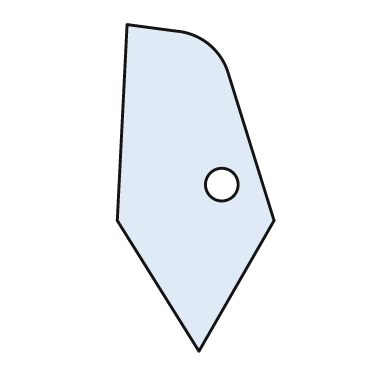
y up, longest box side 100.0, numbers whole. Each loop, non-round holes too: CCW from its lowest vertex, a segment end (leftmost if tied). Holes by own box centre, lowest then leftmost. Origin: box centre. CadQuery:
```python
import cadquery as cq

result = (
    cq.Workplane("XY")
    .moveTo(1.0, -50.0)
    .lineTo(24.0, -10.0)
    .lineTo(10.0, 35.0)
    .threePointArc((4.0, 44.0), (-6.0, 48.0))
    .lineTo(-21.0, 50.0)
    .lineTo(-24.0, -10.0)
    .close()
    .moveTo(8.0, 1.0)
    .circle(5.0)
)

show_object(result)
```